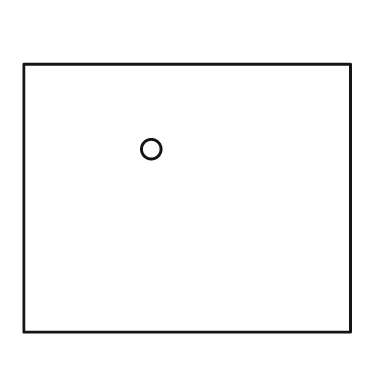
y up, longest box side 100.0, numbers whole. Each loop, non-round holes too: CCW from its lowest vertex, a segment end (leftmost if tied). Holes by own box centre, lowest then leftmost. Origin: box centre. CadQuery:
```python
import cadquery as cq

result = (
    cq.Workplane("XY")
    .moveTo(-50.0, -41.0)
    .lineTo(50.0, -41.0)
    .lineTo(50.0, 41.0)
    .lineTo(-50.0, 41.0)
    .close()
    .moveTo(-11.0, 15.0)
    .circle(3.0)
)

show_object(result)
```